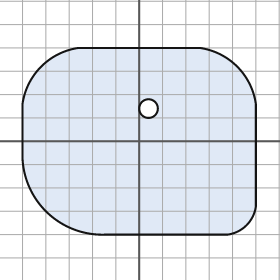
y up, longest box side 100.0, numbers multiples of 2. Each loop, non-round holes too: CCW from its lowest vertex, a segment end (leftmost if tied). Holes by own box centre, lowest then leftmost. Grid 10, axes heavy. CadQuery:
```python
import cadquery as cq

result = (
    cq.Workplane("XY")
    .moveTo(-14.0, -40.0)
    .lineTo(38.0, -40.0)
    .threePointArc((46.0, -36.0), (50.0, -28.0))
    .lineTo(50.0, 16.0)
    .threePointArc((42.0, 32.0), (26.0, 40.0))
    .lineTo(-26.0, 40.0)
    .threePointArc((-42.0, 32.0), (-50.0, 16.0))
    .lineTo(-50.0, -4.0)
    .threePointArc((-40.0, -30.0), (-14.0, -40.0))
    .close()
    .moveTo(4.0, 14.0)
    .circle(4.0)
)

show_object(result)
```